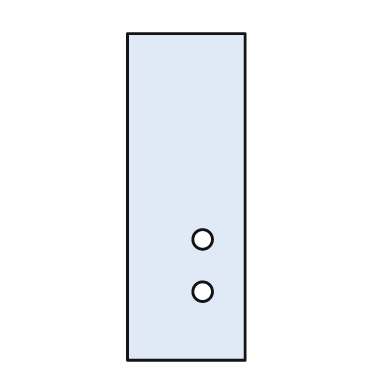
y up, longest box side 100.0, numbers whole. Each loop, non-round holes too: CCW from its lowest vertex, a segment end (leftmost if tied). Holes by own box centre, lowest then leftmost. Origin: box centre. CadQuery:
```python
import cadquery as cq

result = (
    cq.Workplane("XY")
    .moveTo(-18.0, -50.0)
    .lineTo(18.0, -50.0)
    .lineTo(18.0, 50.0)
    .lineTo(-18.0, 50.0)
    .close()
    .moveTo(5.0, -29.0)
    .circle(3.0)
    .moveTo(5.0, -13.0)
    .circle(3.0)
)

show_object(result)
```